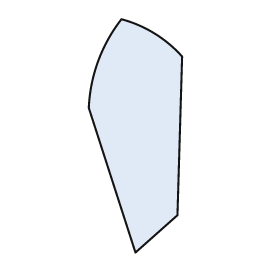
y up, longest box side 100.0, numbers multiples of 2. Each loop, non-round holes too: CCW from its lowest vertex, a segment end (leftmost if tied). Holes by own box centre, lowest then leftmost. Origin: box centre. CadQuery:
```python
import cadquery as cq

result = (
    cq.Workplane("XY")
    .moveTo(0.0, -50.0)
    .lineTo(18.0, -34.0)
    .lineTo(20.0, 34.0)
    .threePointArc((8.0, 44.0), (-6.0, 50.0))
    .threePointArc((-16.0, 32.0), (-20.0, 12.0))
    .close()
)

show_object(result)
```